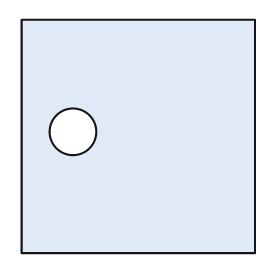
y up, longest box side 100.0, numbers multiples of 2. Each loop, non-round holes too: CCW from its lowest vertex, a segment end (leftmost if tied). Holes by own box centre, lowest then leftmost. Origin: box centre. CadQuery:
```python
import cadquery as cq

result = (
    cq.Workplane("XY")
    .moveTo(-50.0, -50.0)
    .lineTo(50.0, -50.0)
    .lineTo(50.0, 50.0)
    .lineTo(-50.0, 50.0)
    .close()
    .moveTo(-28.0, 2.0)
    .circle(10.0)
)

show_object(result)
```